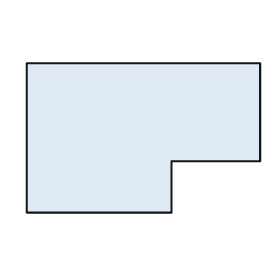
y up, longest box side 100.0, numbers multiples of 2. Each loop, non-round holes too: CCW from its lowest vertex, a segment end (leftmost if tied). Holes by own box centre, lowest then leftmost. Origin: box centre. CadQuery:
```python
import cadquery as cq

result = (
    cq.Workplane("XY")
    .moveTo(-50.0, -32.0)
    .lineTo(12.0, -32.0)
    .lineTo(12.0, -10.0)
    .lineTo(50.0, -10.0)
    .lineTo(50.0, 32.0)
    .lineTo(-50.0, 32.0)
    .close()
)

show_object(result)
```